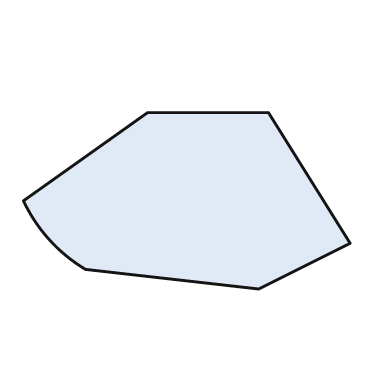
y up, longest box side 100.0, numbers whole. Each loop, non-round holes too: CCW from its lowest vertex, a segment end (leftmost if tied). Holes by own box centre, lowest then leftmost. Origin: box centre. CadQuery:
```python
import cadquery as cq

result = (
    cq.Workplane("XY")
    .moveTo(22.0, -27.0)
    .lineTo(50.0, -13.0)
    .lineTo(25.0, 27.0)
    .lineTo(-12.0, 27.0)
    .lineTo(-50.0, 0.0)
    .threePointArc((-42.0, -12.0), (-31.0, -21.0))
    .close()
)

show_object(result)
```